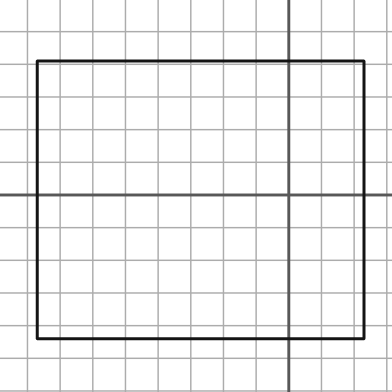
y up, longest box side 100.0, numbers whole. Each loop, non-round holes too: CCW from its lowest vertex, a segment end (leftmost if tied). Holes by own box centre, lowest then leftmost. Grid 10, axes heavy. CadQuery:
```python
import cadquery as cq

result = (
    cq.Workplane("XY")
    .moveTo(-77.0, -44.0)
    .lineTo(23.0, -44.0)
    .lineTo(23.0, 41.0)
    .lineTo(-77.0, 41.0)
    .close()
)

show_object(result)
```